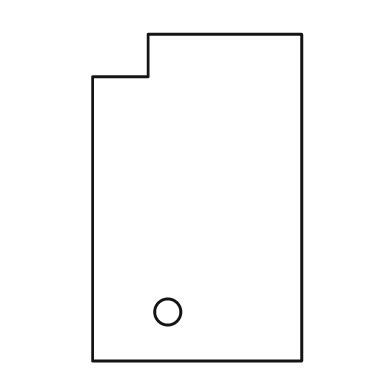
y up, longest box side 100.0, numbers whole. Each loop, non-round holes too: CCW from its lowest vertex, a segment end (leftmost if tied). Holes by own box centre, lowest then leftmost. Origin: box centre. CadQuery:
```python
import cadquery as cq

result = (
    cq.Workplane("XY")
    .moveTo(-32.0, -50.0)
    .lineTo(32.0, -50.0)
    .lineTo(32.0, 50.0)
    .lineTo(-15.0, 50.0)
    .lineTo(-15.0, 37.0)
    .lineTo(-32.0, 37.0)
    .close()
    .moveTo(-9.0, -35.0)
    .circle(4.0)
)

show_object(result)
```